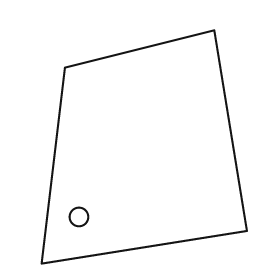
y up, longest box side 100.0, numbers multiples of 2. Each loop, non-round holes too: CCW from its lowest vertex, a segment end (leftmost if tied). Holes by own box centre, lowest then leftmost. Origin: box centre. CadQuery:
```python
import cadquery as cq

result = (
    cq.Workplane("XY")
    .moveTo(-44.0, -50.0)
    .lineTo(44.0, -36.0)
    .lineTo(30.0, 50.0)
    .lineTo(-34.0, 34.0)
    .close()
    .moveTo(-28.0, -30.0)
    .circle(4.0)
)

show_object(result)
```